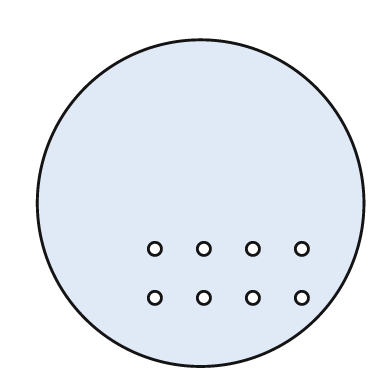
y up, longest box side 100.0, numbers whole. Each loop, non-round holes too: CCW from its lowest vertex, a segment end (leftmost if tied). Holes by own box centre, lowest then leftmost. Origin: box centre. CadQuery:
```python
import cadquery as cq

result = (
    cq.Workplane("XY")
    .moveTo(0.0, 0.0)
    .circle(50.0)
    .moveTo(-14.0, -29.0)
    .circle(2.0)
    .moveTo(1.0, -29.0)
    .circle(2.0)
    .moveTo(16.0, -29.0)
    .circle(2.0)
    .moveTo(31.0, -29.0)
    .circle(2.0)
    .moveTo(-14.0, -14.0)
    .circle(2.0)
    .moveTo(1.0, -14.0)
    .circle(2.0)
    .moveTo(16.0, -14.0)
    .circle(2.0)
    .moveTo(31.0, -14.0)
    .circle(2.0)
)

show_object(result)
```